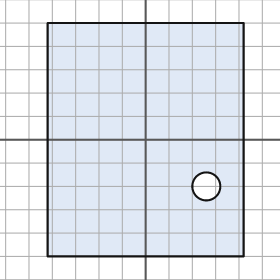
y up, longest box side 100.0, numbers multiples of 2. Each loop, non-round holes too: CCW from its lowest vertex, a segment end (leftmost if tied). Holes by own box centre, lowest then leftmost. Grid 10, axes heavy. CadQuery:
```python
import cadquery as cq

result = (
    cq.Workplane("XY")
    .moveTo(-42.0, -50.0)
    .lineTo(42.0, -50.0)
    .lineTo(42.0, 50.0)
    .lineTo(-42.0, 50.0)
    .close()
    .moveTo(26.0, -20.0)
    .circle(6.0)
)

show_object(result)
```